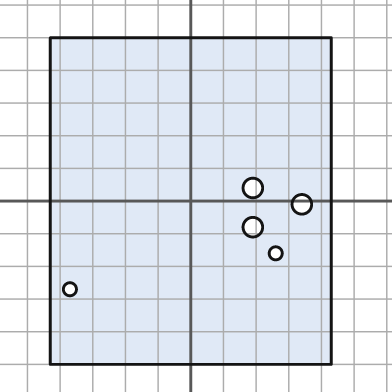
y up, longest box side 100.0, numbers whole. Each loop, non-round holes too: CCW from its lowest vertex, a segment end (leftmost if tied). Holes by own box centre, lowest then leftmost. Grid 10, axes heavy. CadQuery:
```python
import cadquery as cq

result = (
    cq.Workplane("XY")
    .moveTo(-43.0, -50.0)
    .lineTo(43.0, -50.0)
    .lineTo(43.0, 50.0)
    .lineTo(-43.0, 50.0)
    .close()
    .moveTo(-37.0, -27.0)
    .circle(2.0)
    .moveTo(26.0, -16.0)
    .circle(2.0)
    .moveTo(19.0, -8.0)
    .circle(3.0)
    .moveTo(34.0, -1.0)
    .circle(3.0)
    .moveTo(19.0, 4.0)
    .circle(3.0)
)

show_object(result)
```